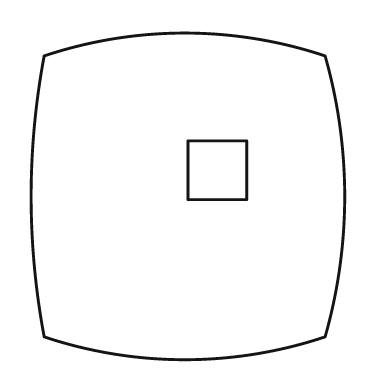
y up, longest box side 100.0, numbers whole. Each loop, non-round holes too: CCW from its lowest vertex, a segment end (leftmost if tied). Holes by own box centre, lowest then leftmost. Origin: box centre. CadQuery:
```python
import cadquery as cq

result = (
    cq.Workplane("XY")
    .moveTo(-44.0, -43.0)
    .threePointArc((-1.0, -50.0), (42.0, -43.0))
    .threePointArc((48.0, 0.0), (42.0, 43.0))
    .threePointArc((-1.0, 50.0), (-44.0, 43.0))
    .threePointArc((-48.0, 0.0), (-44.0, -43.0))
    .close()
    .moveTo(0.0, -1.0)
    .lineTo(18.0, -1.0)
    .lineTo(18.0, 17.0)
    .lineTo(0.0, 17.0)
    .close()
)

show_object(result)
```